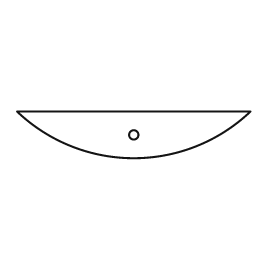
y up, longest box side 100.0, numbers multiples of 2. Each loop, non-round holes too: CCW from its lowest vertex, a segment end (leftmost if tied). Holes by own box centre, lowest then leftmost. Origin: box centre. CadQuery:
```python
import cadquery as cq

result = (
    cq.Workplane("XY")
    .moveTo(-50.0, 10.0)
    .threePointArc((0.0, -10.0), (50.0, 10.0))
    .close()
    .moveTo(0.0, 0.0)
    .circle(2.0)
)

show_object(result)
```